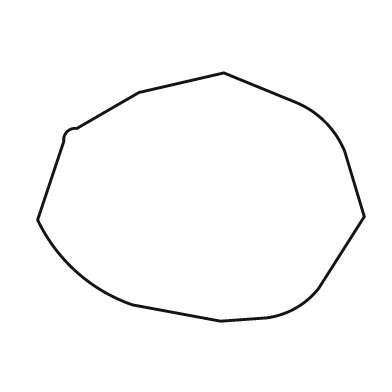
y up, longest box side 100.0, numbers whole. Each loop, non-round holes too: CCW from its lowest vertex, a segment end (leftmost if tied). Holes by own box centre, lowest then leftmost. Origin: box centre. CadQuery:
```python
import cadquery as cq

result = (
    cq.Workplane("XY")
    .moveTo(6.0, -38.0)
    .lineTo(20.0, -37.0)
    .threePointArc((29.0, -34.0), (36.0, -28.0))
    .lineTo(50.0, -6.0)
    .lineTo(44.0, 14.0)
    .threePointArc((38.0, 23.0), (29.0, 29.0))
    .lineTo(7.0, 38.0)
    .lineTo(-19.0, 32.0)
    .lineTo(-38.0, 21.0)
    .threePointArc((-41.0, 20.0), (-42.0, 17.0))
    .lineTo(-50.0, -7.0)
    .threePointArc((-38.0, -23.0), (-21.0, -33.0))
    .close()
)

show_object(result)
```